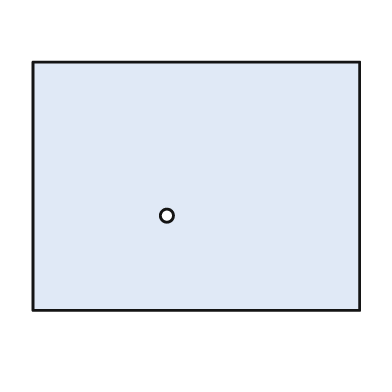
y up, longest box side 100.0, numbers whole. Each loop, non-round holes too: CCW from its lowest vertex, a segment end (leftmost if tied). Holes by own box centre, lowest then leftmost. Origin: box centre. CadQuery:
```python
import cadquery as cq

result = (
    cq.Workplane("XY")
    .moveTo(-50.0, -38.0)
    .lineTo(50.0, -38.0)
    .lineTo(50.0, 38.0)
    .lineTo(-50.0, 38.0)
    .close()
    .moveTo(-9.0, -9.0)
    .circle(2.0)
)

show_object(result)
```